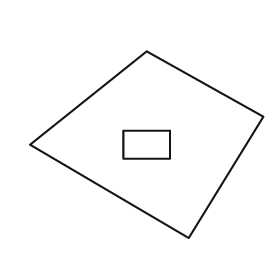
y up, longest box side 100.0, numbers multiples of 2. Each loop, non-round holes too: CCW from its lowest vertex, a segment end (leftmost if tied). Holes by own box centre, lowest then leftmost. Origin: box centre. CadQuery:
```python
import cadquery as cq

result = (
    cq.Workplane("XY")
    .moveTo(18.0, -40.0)
    .lineTo(50.0, 12.0)
    .lineTo(0.0, 40.0)
    .lineTo(-50.0, 0.0)
    .close()
    .moveTo(-10.0, -6.0)
    .lineTo(10.0, -6.0)
    .lineTo(10.0, 6.0)
    .lineTo(-10.0, 6.0)
    .close()
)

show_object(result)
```